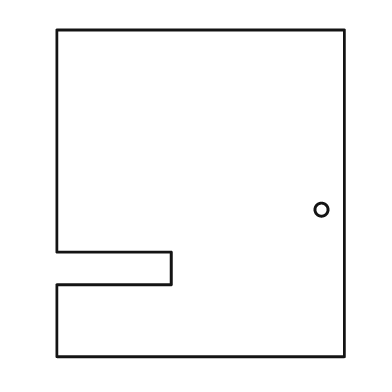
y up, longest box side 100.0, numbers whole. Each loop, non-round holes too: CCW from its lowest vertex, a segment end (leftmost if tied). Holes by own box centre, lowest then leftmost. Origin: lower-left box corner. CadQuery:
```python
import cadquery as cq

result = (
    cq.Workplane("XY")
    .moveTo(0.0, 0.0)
    .lineTo(88.0, 0.0)
    .lineTo(88.0, 100.0)
    .lineTo(0.0, 100.0)
    .lineTo(0.0, 32.0)
    .lineTo(35.0, 32.0)
    .lineTo(35.0, 22.0)
    .lineTo(0.0, 22.0)
    .close()
    .moveTo(81.0, 45.0)
    .circle(2.0)
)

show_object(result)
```